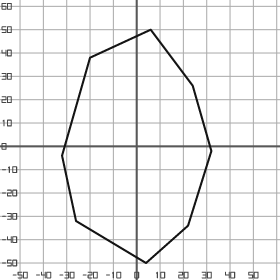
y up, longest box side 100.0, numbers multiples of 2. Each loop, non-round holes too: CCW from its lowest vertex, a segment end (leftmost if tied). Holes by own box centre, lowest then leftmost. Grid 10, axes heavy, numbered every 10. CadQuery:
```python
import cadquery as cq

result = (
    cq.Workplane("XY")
    .moveTo(4.0, -50.0)
    .lineTo(22.0, -34.0)
    .lineTo(32.0, -2.0)
    .lineTo(24.0, 26.0)
    .lineTo(6.0, 50.0)
    .lineTo(-20.0, 38.0)
    .lineTo(-32.0, -4.0)
    .lineTo(-26.0, -32.0)
    .close()
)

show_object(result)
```